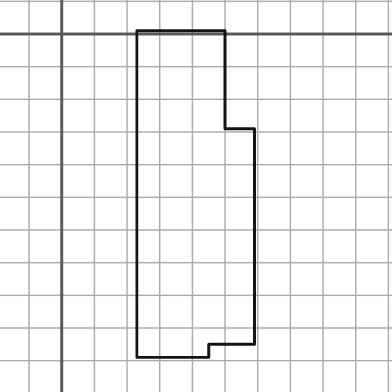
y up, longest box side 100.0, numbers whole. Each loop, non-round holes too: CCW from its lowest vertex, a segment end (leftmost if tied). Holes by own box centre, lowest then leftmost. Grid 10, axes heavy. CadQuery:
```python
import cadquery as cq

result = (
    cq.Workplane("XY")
    .moveTo(23.0, -99.0)
    .lineTo(45.0, -99.0)
    .lineTo(45.0, -95.0)
    .lineTo(59.0, -95.0)
    .lineTo(59.0, -29.0)
    .lineTo(50.0, -29.0)
    .lineTo(50.0, 1.0)
    .lineTo(23.0, 1.0)
    .close()
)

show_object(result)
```